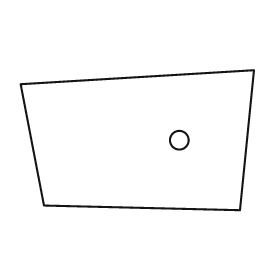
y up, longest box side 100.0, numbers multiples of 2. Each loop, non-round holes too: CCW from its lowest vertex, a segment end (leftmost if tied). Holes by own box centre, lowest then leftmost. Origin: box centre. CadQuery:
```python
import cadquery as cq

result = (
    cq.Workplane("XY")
    .moveTo(44.0, -30.0)
    .lineTo(50.0, 30.0)
    .lineTo(-50.0, 24.0)
    .lineTo(-40.0, -28.0)
    .close()
    .moveTo(18.0, 0.0)
    .circle(4.0)
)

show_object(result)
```